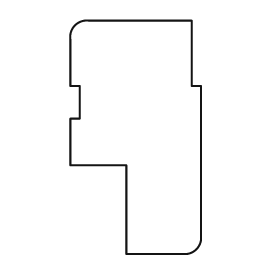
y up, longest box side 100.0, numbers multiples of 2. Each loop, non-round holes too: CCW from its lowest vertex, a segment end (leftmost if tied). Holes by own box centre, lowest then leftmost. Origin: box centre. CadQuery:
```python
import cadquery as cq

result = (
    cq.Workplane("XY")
    .moveTo(-4.0, -50.0)
    .lineTo(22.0, -50.0)
    .threePointArc((26.0, -48.0), (28.0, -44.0))
    .lineTo(28.0, 22.0)
    .lineTo(24.0, 22.0)
    .lineTo(24.0, 50.0)
    .lineTo(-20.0, 50.0)
    .threePointArc((-26.0, 48.0), (-28.0, 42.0))
    .lineTo(-28.0, 22.0)
    .lineTo(-24.0, 22.0)
    .lineTo(-24.0, 8.0)
    .lineTo(-28.0, 8.0)
    .lineTo(-28.0, -12.0)
    .lineTo(-4.0, -12.0)
    .close()
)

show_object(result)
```